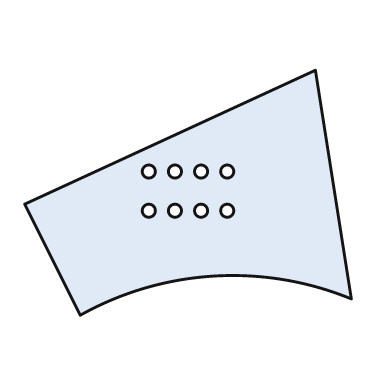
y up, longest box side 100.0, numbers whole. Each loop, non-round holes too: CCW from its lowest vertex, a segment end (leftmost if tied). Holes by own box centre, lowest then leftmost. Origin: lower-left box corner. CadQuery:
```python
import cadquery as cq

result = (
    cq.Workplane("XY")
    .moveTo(17.0, 0.0)
    .threePointArc((58.0, 12.0), (100.0, 5.0))
    .lineTo(89.0, 75.0)
    .lineTo(0.0, 34.0)
    .close()
    .moveTo(38.0, 32.0)
    .circle(2.0)
    .moveTo(46.0, 32.0)
    .circle(2.0)
    .moveTo(54.0, 32.0)
    .circle(2.0)
    .moveTo(62.0, 32.0)
    .circle(2.0)
    .moveTo(38.0, 44.0)
    .circle(2.0)
    .moveTo(46.0, 44.0)
    .circle(2.0)
    .moveTo(54.0, 44.0)
    .circle(2.0)
    .moveTo(62.0, 44.0)
    .circle(2.0)
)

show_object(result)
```